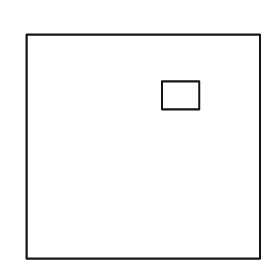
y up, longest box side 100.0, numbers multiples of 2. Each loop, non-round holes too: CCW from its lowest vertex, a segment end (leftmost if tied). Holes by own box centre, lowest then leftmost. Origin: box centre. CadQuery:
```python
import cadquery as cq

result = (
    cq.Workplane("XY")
    .moveTo(-50.0, -48.0)
    .lineTo(50.0, -48.0)
    .lineTo(50.0, 48.0)
    .lineTo(-50.0, 48.0)
    .close()
    .moveTo(8.0, 16.0)
    .lineTo(24.0, 16.0)
    .lineTo(24.0, 28.0)
    .lineTo(8.0, 28.0)
    .close()
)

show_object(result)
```